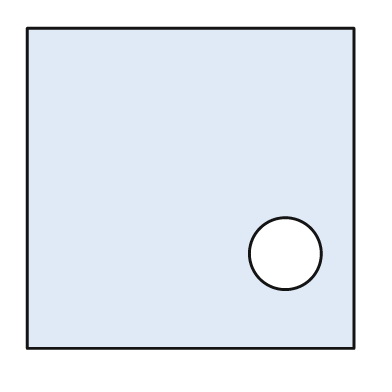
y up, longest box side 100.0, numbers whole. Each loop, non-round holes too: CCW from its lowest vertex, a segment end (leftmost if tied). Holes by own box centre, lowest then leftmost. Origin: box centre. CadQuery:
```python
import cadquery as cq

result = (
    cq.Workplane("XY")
    .moveTo(-50.0, -49.0)
    .lineTo(50.0, -49.0)
    .lineTo(50.0, 49.0)
    .lineTo(-50.0, 49.0)
    .close()
    .moveTo(29.0, -20.0)
    .circle(11.0)
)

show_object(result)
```